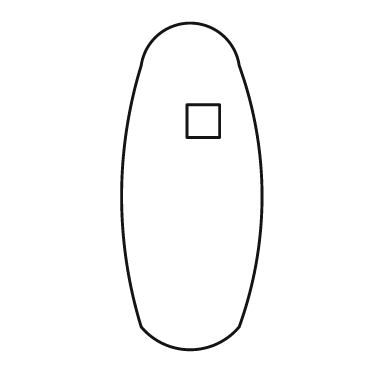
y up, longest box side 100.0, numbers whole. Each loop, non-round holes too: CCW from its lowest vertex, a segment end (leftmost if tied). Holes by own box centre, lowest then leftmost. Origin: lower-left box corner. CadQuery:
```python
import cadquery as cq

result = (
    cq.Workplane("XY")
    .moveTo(6.0, 7.0)
    .threePointArc((21.0, 0.0), (36.0, 7.0))
    .threePointArc((43.0, 47.0), (36.0, 87.0))
    .threePointArc((21.0, 100.0), (6.0, 87.0))
    .threePointArc((0.0, 47.0), (6.0, 7.0))
    .close()
    .moveTo(20.0, 65.0)
    .lineTo(30.0, 65.0)
    .lineTo(30.0, 75.0)
    .lineTo(20.0, 75.0)
    .close()
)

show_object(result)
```